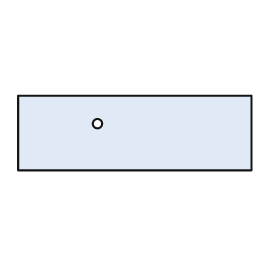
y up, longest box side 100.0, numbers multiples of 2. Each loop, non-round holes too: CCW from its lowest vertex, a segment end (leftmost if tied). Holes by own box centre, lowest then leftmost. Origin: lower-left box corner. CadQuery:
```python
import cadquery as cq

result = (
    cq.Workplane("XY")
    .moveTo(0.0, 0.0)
    .lineTo(100.0, 0.0)
    .lineTo(100.0, 32.0)
    .lineTo(0.0, 32.0)
    .close()
    .moveTo(34.0, 20.0)
    .circle(2.0)
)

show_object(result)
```